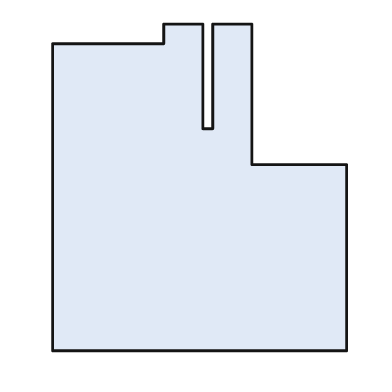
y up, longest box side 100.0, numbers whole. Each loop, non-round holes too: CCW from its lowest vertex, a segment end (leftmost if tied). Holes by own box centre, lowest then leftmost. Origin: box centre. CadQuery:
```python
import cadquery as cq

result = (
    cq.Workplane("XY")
    .moveTo(-45.0, -50.0)
    .lineTo(45.0, -50.0)
    .lineTo(45.0, 7.0)
    .lineTo(16.0, 7.0)
    .lineTo(16.0, 50.0)
    .lineTo(4.0, 50.0)
    .lineTo(4.0, 18.0)
    .lineTo(1.0, 18.0)
    .lineTo(1.0, 50.0)
    .lineTo(-11.0, 50.0)
    .lineTo(-11.0, 44.0)
    .lineTo(-45.0, 44.0)
    .close()
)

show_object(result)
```